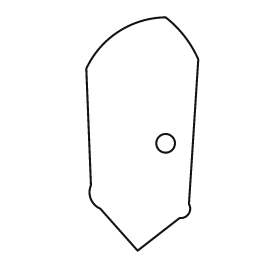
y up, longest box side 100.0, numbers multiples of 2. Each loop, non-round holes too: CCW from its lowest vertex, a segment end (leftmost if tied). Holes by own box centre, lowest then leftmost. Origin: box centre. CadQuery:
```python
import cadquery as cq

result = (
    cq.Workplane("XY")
    .moveTo(-2.0, -50.0)
    .lineTo(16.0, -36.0)
    .threePointArc((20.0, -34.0), (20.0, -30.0))
    .lineTo(24.0, 32.0)
    .threePointArc((18.0, 42.0), (10.0, 50.0))
    .threePointArc((-10.0, 44.0), (-24.0, 28.0))
    .lineTo(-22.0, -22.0)
    .threePointArc((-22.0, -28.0), (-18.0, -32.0))
    .close()
    .moveTo(10.0, -4.0)
    .circle(4.0)
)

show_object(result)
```